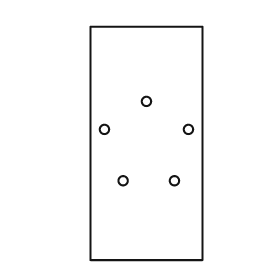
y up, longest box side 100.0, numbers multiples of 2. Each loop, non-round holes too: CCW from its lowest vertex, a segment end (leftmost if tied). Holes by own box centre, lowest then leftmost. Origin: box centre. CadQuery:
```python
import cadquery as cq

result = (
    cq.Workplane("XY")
    .moveTo(-24.0, -50.0)
    .lineTo(24.0, -50.0)
    .lineTo(24.0, 50.0)
    .lineTo(-24.0, 50.0)
    .close()
    .moveTo(-10.0, -16.0)
    .circle(2.0)
    .moveTo(12.0, -16.0)
    .circle(2.0)
    .moveTo(-18.0, 6.0)
    .circle(2.0)
    .moveTo(18.0, 6.0)
    .circle(2.0)
    .moveTo(0.0, 18.0)
    .circle(2.0)
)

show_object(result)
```